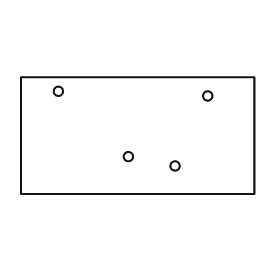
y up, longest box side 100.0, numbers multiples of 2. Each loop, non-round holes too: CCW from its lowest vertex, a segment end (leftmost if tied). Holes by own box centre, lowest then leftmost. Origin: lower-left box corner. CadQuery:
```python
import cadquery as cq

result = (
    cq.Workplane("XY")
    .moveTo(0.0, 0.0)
    .lineTo(100.0, 0.0)
    .lineTo(100.0, 50.0)
    .lineTo(0.0, 50.0)
    .close()
    .moveTo(66.0, 12.0)
    .circle(2.0)
    .moveTo(46.0, 16.0)
    .circle(2.0)
    .moveTo(80.0, 42.0)
    .circle(2.0)
    .moveTo(16.0, 44.0)
    .circle(2.0)
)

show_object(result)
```